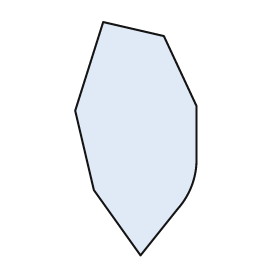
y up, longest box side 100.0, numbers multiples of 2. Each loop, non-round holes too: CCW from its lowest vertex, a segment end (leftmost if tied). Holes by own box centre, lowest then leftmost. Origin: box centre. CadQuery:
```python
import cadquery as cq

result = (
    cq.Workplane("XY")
    .moveTo(2.0, -50.0)
    .lineTo(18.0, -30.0)
    .threePointArc((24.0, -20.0), (26.0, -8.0))
    .lineTo(26.0, 14.0)
    .lineTo(12.0, 44.0)
    .lineTo(-14.0, 50.0)
    .lineTo(-26.0, 12.0)
    .lineTo(-18.0, -22.0)
    .close()
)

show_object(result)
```